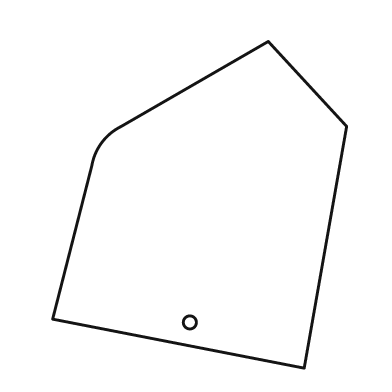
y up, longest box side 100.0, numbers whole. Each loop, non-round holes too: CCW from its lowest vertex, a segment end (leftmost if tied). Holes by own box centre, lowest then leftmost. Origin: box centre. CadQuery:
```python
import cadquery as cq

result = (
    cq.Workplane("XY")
    .moveTo(32.0, -50.0)
    .lineTo(45.0, 24.0)
    .lineTo(21.0, 50.0)
    .lineTo(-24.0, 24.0)
    .threePointArc((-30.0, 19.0), (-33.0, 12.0))
    .lineTo(-45.0, -35.0)
    .close()
    .moveTo(-3.0, -36.0)
    .circle(2.0)
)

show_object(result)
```